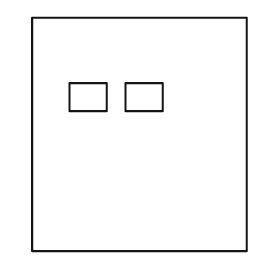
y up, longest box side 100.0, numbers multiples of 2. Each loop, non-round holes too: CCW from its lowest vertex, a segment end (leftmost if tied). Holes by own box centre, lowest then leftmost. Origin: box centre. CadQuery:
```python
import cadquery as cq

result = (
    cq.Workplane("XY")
    .moveTo(-46.0, -50.0)
    .lineTo(46.0, -50.0)
    .lineTo(46.0, 50.0)
    .lineTo(-46.0, 50.0)
    .close()
    .moveTo(-30.0, 10.0)
    .lineTo(-14.0, 10.0)
    .lineTo(-14.0, 22.0)
    .lineTo(-30.0, 22.0)
    .close()
    .moveTo(-6.0, 10.0)
    .lineTo(10.0, 10.0)
    .lineTo(10.0, 22.0)
    .lineTo(-6.0, 22.0)
    .close()
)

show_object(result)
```